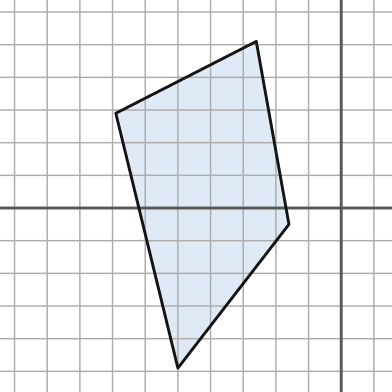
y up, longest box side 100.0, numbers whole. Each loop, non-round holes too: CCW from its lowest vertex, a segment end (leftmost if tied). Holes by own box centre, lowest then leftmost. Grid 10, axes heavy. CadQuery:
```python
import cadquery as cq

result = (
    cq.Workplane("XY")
    .moveTo(-50.0, -49.0)
    .lineTo(-16.0, -5.0)
    .lineTo(-26.0, 51.0)
    .lineTo(-69.0, 29.0)
    .close()
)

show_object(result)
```